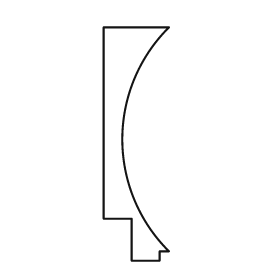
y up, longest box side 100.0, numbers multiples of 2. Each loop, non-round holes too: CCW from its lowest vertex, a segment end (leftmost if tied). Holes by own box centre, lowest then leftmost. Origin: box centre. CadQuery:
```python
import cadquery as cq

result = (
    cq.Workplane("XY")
    .moveTo(-2.0, -50.0)
    .lineTo(10.0, -50.0)
    .lineTo(10.0, -46.0)
    .lineTo(14.0, -46.0)
    .threePointArc((-6.0, 2.0), (14.0, 50.0))
    .lineTo(-14.0, 50.0)
    .lineTo(-14.0, -32.0)
    .lineTo(-2.0, -32.0)
    .close()
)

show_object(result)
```